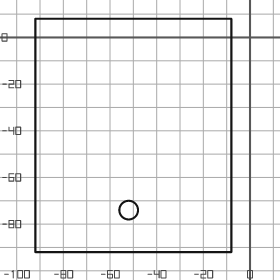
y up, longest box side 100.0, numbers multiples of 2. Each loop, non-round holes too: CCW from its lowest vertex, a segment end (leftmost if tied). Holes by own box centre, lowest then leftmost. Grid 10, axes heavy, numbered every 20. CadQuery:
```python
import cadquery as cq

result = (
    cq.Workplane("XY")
    .moveTo(-92.0, -92.0)
    .lineTo(-8.0, -92.0)
    .lineTo(-8.0, 8.0)
    .lineTo(-92.0, 8.0)
    .close()
    .moveTo(-52.0, -74.0)
    .circle(4.0)
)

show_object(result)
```